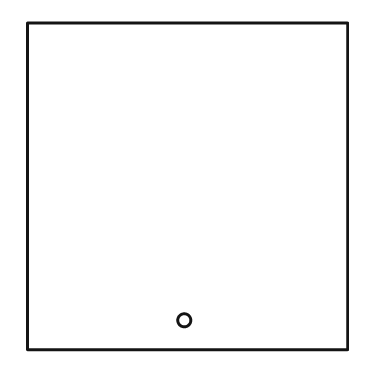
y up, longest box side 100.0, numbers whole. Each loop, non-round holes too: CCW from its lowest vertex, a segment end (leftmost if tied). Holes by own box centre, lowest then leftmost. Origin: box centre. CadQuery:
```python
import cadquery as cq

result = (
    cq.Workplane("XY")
    .moveTo(-49.0, -50.0)
    .lineTo(49.0, -50.0)
    .lineTo(49.0, 50.0)
    .lineTo(-49.0, 50.0)
    .close()
    .moveTo(-1.0, -41.0)
    .circle(2.0)
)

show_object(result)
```